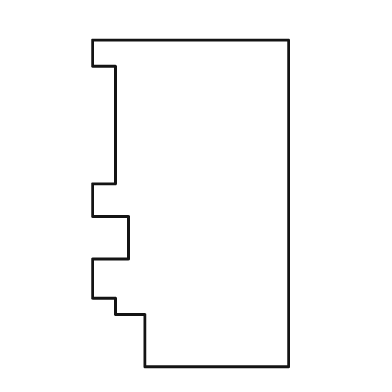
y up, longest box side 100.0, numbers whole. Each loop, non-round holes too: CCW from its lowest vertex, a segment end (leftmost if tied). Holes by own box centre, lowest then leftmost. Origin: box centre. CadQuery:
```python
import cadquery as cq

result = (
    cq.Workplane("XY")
    .moveTo(-14.0, -50.0)
    .lineTo(30.0, -50.0)
    .lineTo(30.0, 50.0)
    .lineTo(-30.0, 50.0)
    .lineTo(-30.0, 42.0)
    .lineTo(-23.0, 42.0)
    .lineTo(-23.0, 6.0)
    .lineTo(-30.0, 6.0)
    .lineTo(-30.0, -4.0)
    .lineTo(-19.0, -4.0)
    .lineTo(-19.0, -17.0)
    .lineTo(-30.0, -17.0)
    .lineTo(-30.0, -29.0)
    .lineTo(-23.0, -29.0)
    .lineTo(-23.0, -34.0)
    .lineTo(-14.0, -34.0)
    .close()
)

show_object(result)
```